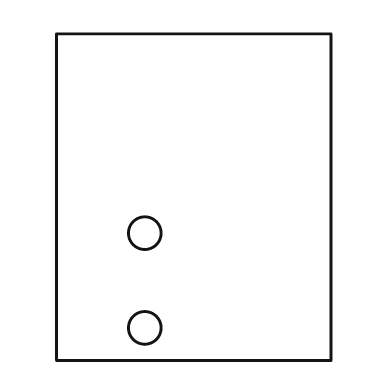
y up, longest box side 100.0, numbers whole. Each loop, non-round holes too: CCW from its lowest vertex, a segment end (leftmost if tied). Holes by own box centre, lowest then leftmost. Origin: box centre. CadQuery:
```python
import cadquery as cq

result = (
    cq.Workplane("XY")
    .moveTo(-42.0, -50.0)
    .lineTo(42.0, -50.0)
    .lineTo(42.0, 50.0)
    .lineTo(-42.0, 50.0)
    .close()
    .moveTo(-15.0, -40.0)
    .circle(5.0)
    .moveTo(-15.0, -11.0)
    .circle(5.0)
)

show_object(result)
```